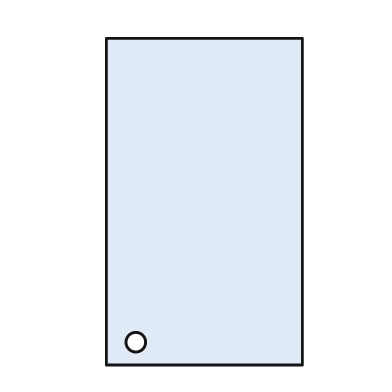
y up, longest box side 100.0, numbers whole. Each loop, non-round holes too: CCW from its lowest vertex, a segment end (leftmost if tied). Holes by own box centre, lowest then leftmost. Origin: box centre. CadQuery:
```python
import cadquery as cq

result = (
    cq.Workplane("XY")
    .moveTo(-30.0, -50.0)
    .lineTo(30.0, -50.0)
    .lineTo(30.0, 50.0)
    .lineTo(-30.0, 50.0)
    .close()
    .moveTo(-21.0, -43.0)
    .circle(3.0)
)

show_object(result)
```